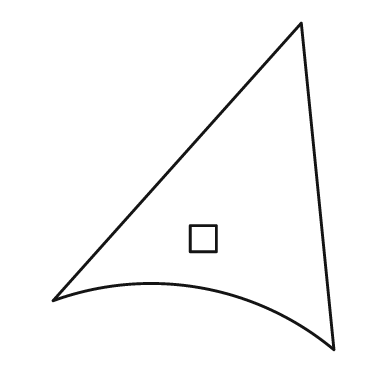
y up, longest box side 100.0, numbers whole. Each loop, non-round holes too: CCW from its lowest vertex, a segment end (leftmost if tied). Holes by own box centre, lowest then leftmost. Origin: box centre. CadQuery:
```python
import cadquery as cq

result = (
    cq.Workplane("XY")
    .moveTo(43.0, -50.0)
    .lineTo(33.0, 50.0)
    .lineTo(-43.0, -35.0)
    .threePointArc((2.0, -31.0), (43.0, -50.0))
    .close()
    .moveTo(-1.0, -20.0)
    .lineTo(7.0, -20.0)
    .lineTo(7.0, -12.0)
    .lineTo(-1.0, -12.0)
    .close()
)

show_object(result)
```